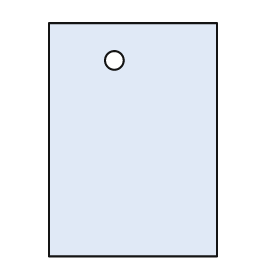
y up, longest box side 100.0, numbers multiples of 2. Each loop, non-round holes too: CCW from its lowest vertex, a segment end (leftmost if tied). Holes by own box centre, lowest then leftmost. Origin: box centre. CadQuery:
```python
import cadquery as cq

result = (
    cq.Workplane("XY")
    .moveTo(-36.0, -50.0)
    .lineTo(36.0, -50.0)
    .lineTo(36.0, 50.0)
    .lineTo(-36.0, 50.0)
    .close()
    .moveTo(-8.0, 34.0)
    .circle(4.0)
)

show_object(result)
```